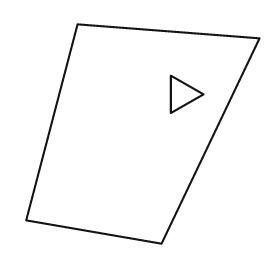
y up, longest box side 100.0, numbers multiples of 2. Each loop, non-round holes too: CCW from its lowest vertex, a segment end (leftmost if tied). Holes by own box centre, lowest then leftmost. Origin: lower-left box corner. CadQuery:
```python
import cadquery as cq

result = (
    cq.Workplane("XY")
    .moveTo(58.0, 0.0)
    .lineTo(100.0, 88.0)
    .lineTo(22.0, 94.0)
    .lineTo(0.0, 10.0)
    .close()
    .moveTo(62.0, 56.0)
    .lineTo(76.0, 64.0)
    .lineTo(62.0, 72.0)
    .close()
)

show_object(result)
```